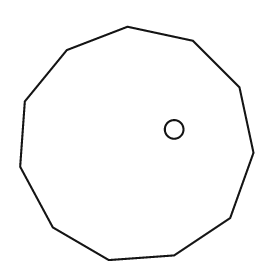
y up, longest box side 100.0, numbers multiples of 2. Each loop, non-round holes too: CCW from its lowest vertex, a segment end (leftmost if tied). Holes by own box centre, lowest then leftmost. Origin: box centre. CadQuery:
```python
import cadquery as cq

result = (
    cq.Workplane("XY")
    .moveTo(-12.0, -50.0)
    .lineTo(16.0, -48.0)
    .lineTo(40.0, -32.0)
    .lineTo(50.0, -4.0)
    .lineTo(44.0, 24.0)
    .lineTo(24.0, 44.0)
    .lineTo(-4.0, 50.0)
    .lineTo(-30.0, 40.0)
    .lineTo(-48.0, 18.0)
    .lineTo(-50.0, -10.0)
    .lineTo(-36.0, -36.0)
    .close()
    .moveTo(16.0, 6.0)
    .circle(4.0)
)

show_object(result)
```